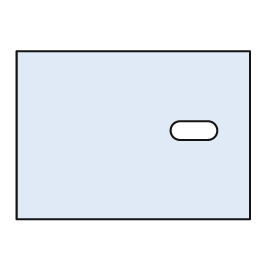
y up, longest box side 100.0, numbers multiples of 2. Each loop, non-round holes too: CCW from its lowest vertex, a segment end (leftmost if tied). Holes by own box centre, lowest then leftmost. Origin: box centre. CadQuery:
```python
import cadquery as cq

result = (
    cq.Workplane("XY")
    .moveTo(-50.0, -36.0)
    .lineTo(50.0, -36.0)
    .lineTo(50.0, 36.0)
    .lineTo(-50.0, 36.0)
    .close()
    .moveTo(20.0, -2.0)
    .lineTo(32.0, -2.0)
    .threePointArc((36.0, 2.0), (32.0, 6.0))
    .lineTo(20.0, 6.0)
    .threePointArc((16.0, 2.0), (20.0, -2.0))
    .close()
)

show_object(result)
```